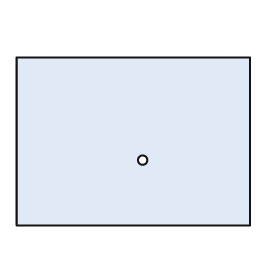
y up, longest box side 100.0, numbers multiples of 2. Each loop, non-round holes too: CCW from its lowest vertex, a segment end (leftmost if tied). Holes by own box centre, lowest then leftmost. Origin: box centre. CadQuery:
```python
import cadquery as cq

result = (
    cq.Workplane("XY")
    .moveTo(-50.0, -36.0)
    .lineTo(50.0, -36.0)
    .lineTo(50.0, 36.0)
    .lineTo(-50.0, 36.0)
    .close()
    .moveTo(4.0, -8.0)
    .circle(2.0)
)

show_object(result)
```